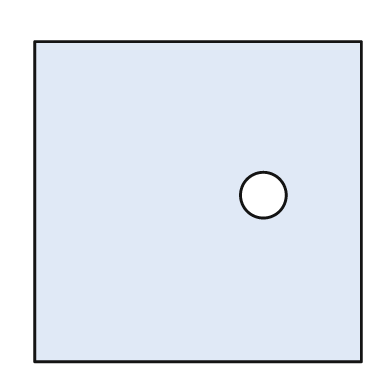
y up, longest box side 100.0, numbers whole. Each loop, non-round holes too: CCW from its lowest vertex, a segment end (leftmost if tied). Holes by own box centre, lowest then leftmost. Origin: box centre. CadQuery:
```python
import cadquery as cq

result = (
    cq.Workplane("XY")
    .moveTo(-50.0, -49.0)
    .lineTo(50.0, -49.0)
    .lineTo(50.0, 49.0)
    .lineTo(-50.0, 49.0)
    .close()
    .moveTo(20.0, 2.0)
    .circle(7.0)
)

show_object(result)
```